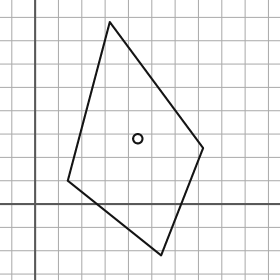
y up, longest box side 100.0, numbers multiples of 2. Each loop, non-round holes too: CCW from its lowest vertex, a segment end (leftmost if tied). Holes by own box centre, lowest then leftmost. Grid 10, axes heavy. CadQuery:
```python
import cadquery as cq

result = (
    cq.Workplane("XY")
    .moveTo(54.0, -22.0)
    .lineTo(72.0, 24.0)
    .lineTo(32.0, 78.0)
    .lineTo(14.0, 10.0)
    .close()
    .moveTo(44.0, 28.0)
    .circle(2.0)
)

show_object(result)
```